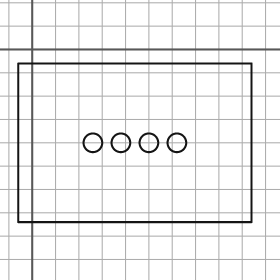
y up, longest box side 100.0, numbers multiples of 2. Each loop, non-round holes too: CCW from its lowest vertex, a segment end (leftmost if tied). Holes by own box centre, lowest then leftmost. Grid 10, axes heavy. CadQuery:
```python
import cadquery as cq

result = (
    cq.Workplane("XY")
    .moveTo(-6.0, -74.0)
    .lineTo(94.0, -74.0)
    .lineTo(94.0, -6.0)
    .lineTo(-6.0, -6.0)
    .close()
    .moveTo(26.0, -40.0)
    .circle(4.0)
    .moveTo(38.0, -40.0)
    .circle(4.0)
    .moveTo(50.0, -40.0)
    .circle(4.0)
    .moveTo(62.0, -40.0)
    .circle(4.0)
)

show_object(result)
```